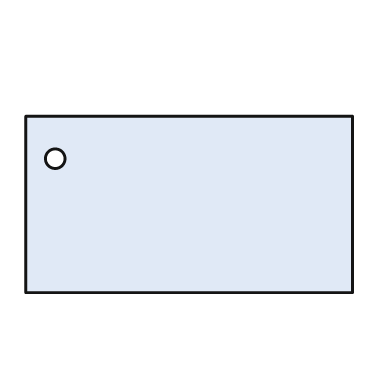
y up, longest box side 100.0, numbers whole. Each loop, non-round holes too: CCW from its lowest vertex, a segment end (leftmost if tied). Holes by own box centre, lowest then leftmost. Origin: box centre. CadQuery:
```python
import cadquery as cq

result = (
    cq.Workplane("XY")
    .moveTo(-50.0, -27.0)
    .lineTo(50.0, -27.0)
    .lineTo(50.0, 27.0)
    .lineTo(-50.0, 27.0)
    .close()
    .moveTo(-41.0, 14.0)
    .circle(3.0)
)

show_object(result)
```